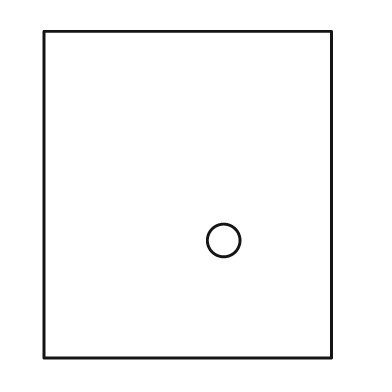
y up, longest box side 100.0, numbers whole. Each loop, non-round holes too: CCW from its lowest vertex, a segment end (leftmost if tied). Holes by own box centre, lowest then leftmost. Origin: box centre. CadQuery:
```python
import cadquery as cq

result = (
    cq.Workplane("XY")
    .moveTo(-44.0, -50.0)
    .lineTo(44.0, -50.0)
    .lineTo(44.0, 50.0)
    .lineTo(-44.0, 50.0)
    .close()
    .moveTo(11.0, -14.0)
    .circle(5.0)
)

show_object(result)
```